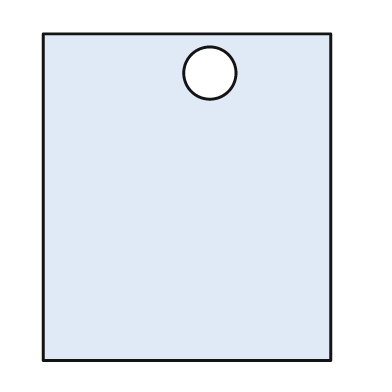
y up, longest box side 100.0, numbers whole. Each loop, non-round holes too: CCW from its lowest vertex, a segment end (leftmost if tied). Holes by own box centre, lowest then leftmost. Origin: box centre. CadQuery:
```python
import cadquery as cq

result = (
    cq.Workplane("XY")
    .moveTo(-44.0, -50.0)
    .lineTo(44.0, -50.0)
    .lineTo(44.0, 50.0)
    .lineTo(-44.0, 50.0)
    .close()
    .moveTo(7.0, 38.0)
    .circle(8.0)
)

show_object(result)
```